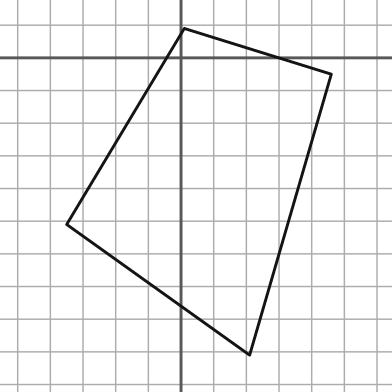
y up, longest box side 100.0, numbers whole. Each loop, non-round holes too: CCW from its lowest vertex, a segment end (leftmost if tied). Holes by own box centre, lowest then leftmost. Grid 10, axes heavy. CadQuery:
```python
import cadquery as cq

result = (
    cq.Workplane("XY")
    .moveTo(21.0, -91.0)
    .lineTo(46.0, -5.0)
    .lineTo(1.0, 9.0)
    .lineTo(-35.0, -51.0)
    .close()
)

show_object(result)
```